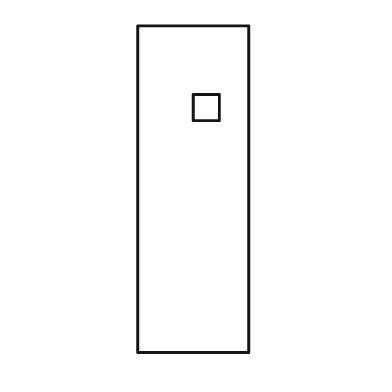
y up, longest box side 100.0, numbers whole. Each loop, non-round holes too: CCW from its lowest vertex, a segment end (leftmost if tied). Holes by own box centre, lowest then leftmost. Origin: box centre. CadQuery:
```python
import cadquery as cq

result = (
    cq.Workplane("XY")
    .moveTo(-17.0, -50.0)
    .lineTo(17.0, -50.0)
    .lineTo(17.0, 50.0)
    .lineTo(-17.0, 50.0)
    .close()
    .moveTo(0.0, 21.0)
    .lineTo(8.0, 21.0)
    .lineTo(8.0, 29.0)
    .lineTo(0.0, 29.0)
    .close()
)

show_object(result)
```